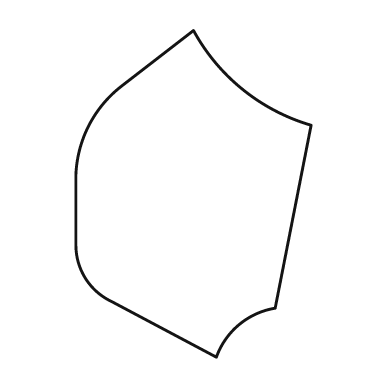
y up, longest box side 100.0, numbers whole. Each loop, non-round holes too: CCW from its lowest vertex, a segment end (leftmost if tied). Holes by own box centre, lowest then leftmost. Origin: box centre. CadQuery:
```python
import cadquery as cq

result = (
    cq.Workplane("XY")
    .moveTo(7.0, -50.0)
    .threePointArc((14.0, -40.0), (25.0, -35.0))
    .lineTo(36.0, 21.0)
    .threePointArc((15.0, 32.0), (0.0, 50.0))
    .lineTo(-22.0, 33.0)
    .threePointArc((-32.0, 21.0), (-36.0, 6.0))
    .lineTo(-36.0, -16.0)
    .threePointArc((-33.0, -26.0), (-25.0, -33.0))
    .close()
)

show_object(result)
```